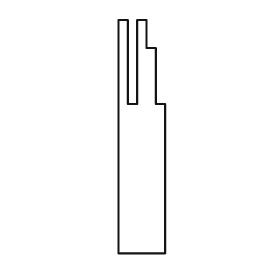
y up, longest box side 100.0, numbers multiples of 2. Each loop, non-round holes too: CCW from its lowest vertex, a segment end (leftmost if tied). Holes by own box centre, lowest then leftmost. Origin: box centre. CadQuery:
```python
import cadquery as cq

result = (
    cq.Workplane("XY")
    .moveTo(-10.0, -50.0)
    .lineTo(10.0, -50.0)
    .lineTo(10.0, 14.0)
    .lineTo(6.0, 14.0)
    .lineTo(6.0, 38.0)
    .lineTo(2.0, 38.0)
    .lineTo(2.0, 50.0)
    .lineTo(-2.0, 50.0)
    .lineTo(-2.0, 14.0)
    .lineTo(-6.0, 14.0)
    .lineTo(-6.0, 50.0)
    .lineTo(-10.0, 50.0)
    .close()
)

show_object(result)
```